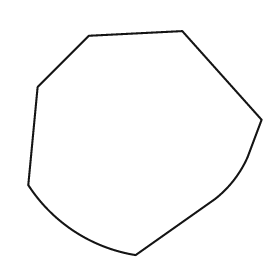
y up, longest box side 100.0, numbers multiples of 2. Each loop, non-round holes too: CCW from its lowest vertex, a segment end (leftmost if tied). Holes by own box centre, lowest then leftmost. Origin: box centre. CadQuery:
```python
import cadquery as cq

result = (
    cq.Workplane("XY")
    .moveTo(-4.0, -48.0)
    .lineTo(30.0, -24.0)
    .threePointArc((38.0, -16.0), (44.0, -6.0))
    .lineTo(50.0, 10.0)
    .lineTo(16.0, 48.0)
    .lineTo(-24.0, 46.0)
    .lineTo(-46.0, 24.0)
    .lineTo(-50.0, -18.0)
    .threePointArc((-30.0, -38.0), (-4.0, -48.0))
    .close()
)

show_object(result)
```